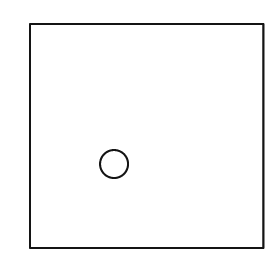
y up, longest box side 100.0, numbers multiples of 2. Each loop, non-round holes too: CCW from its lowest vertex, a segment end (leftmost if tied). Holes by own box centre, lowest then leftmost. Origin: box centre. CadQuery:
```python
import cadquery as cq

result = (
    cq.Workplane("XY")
    .moveTo(-50.0, -48.0)
    .lineTo(50.0, -48.0)
    .lineTo(50.0, 48.0)
    .lineTo(-50.0, 48.0)
    .close()
    .moveTo(-14.0, -12.0)
    .circle(6.0)
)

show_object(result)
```